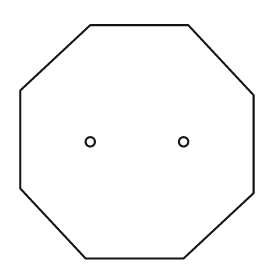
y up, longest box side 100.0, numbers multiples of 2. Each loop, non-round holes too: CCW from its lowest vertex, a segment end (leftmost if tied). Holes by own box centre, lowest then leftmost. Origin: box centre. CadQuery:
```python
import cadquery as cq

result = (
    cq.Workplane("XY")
    .moveTo(-22.0, -50.0)
    .lineTo(20.0, -50.0)
    .lineTo(50.0, -22.0)
    .lineTo(50.0, 20.0)
    .lineTo(22.0, 50.0)
    .lineTo(-20.0, 50.0)
    .lineTo(-50.0, 22.0)
    .lineTo(-50.0, -20.0)
    .close()
    .moveTo(-20.0, 0.0)
    .circle(2.0)
    .moveTo(20.0, 0.0)
    .circle(2.0)
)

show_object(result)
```